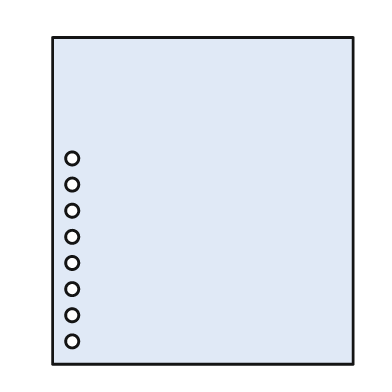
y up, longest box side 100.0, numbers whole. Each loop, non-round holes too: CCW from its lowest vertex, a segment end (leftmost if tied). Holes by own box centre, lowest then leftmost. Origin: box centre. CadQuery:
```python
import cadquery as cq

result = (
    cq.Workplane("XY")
    .moveTo(-46.0, -50.0)
    .lineTo(46.0, -50.0)
    .lineTo(46.0, 50.0)
    .lineTo(-46.0, 50.0)
    .close()
    .moveTo(-40.0, -43.0)
    .circle(2.0)
    .moveTo(-40.0, -35.0)
    .circle(2.0)
    .moveTo(-40.0, -27.0)
    .circle(2.0)
    .moveTo(-40.0, -19.0)
    .circle(2.0)
    .moveTo(-40.0, -11.0)
    .circle(2.0)
    .moveTo(-40.0, -3.0)
    .circle(2.0)
    .moveTo(-40.0, 5.0)
    .circle(2.0)
    .moveTo(-40.0, 13.0)
    .circle(2.0)
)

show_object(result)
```